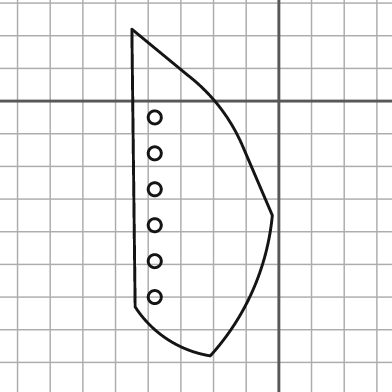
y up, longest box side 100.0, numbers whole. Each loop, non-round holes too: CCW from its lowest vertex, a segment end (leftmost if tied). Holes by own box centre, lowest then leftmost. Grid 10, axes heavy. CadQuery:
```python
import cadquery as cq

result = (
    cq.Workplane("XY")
    .moveTo(-21.0, -78.0)
    .threePointArc((-8.0, -58.0), (-2.0, -35.0))
    .lineTo(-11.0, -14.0)
    .threePointArc((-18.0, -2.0), (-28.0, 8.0))
    .lineTo(-45.0, 22.0)
    .lineTo(-44.0, -63.0)
    .threePointArc((-34.0, -73.0), (-21.0, -78.0))
    .close()
    .moveTo(-38.0, -60.0)
    .circle(2.0)
    .moveTo(-38.0, -49.0)
    .circle(2.0)
    .moveTo(-38.0, -38.0)
    .circle(2.0)
    .moveTo(-38.0, -27.0)
    .circle(2.0)
    .moveTo(-38.0, -16.0)
    .circle(2.0)
    .moveTo(-38.0, -5.0)
    .circle(2.0)
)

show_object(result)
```